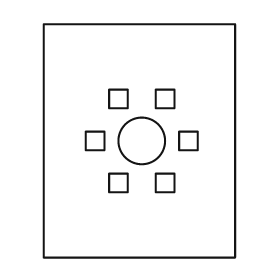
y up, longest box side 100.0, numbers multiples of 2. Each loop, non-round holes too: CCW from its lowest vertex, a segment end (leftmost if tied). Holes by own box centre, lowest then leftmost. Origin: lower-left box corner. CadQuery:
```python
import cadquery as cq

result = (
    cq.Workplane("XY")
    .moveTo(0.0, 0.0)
    .lineTo(82.0, 0.0)
    .lineTo(82.0, 100.0)
    .lineTo(0.0, 100.0)
    .close()
    .moveTo(28.0, 28.0)
    .lineTo(36.0, 28.0)
    .lineTo(36.0, 36.0)
    .lineTo(28.0, 36.0)
    .close()
    .moveTo(48.0, 28.0)
    .lineTo(56.0, 28.0)
    .lineTo(56.0, 36.0)
    .lineTo(48.0, 36.0)
    .close()
    .moveTo(18.0, 46.0)
    .lineTo(26.0, 46.0)
    .lineTo(26.0, 54.0)
    .lineTo(18.0, 54.0)
    .close()
    .moveTo(42.0, 50.0)
    .circle(10.0)
    .moveTo(58.0, 46.0)
    .lineTo(66.0, 46.0)
    .lineTo(66.0, 54.0)
    .lineTo(58.0, 54.0)
    .close()
    .moveTo(28.0, 64.0)
    .lineTo(36.0, 64.0)
    .lineTo(36.0, 72.0)
    .lineTo(28.0, 72.0)
    .close()
    .moveTo(48.0, 64.0)
    .lineTo(56.0, 64.0)
    .lineTo(56.0, 72.0)
    .lineTo(48.0, 72.0)
    .close()
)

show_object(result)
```